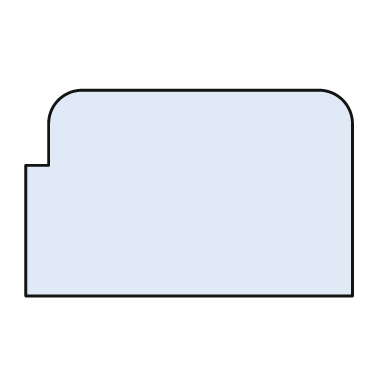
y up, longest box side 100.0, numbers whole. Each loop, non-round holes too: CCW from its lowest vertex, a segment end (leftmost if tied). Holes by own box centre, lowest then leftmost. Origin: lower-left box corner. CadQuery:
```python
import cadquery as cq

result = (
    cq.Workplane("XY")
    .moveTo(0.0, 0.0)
    .lineTo(100.0, 0.0)
    .lineTo(100.0, 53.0)
    .threePointArc((97.0, 60.0), (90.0, 63.0))
    .lineTo(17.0, 63.0)
    .threePointArc((10.0, 60.0), (7.0, 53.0))
    .lineTo(7.0, 40.0)
    .lineTo(0.0, 40.0)
    .close()
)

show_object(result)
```